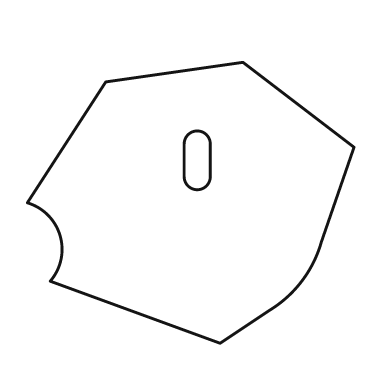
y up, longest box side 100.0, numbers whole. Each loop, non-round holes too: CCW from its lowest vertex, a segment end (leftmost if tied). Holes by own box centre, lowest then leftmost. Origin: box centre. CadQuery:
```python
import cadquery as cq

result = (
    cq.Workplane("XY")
    .moveTo(9.0, -43.0)
    .lineTo(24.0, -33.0)
    .threePointArc((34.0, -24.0), (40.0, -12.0))
    .lineTo(50.0, 17.0)
    .lineTo(16.0, 43.0)
    .lineTo(-26.0, 37.0)
    .lineTo(-50.0, 0.0)
    .threePointArc((-40.0, -10.0), (-43.0, -24.0))
    .close()
    .moveTo(-2.0, 8.0)
    .threePointArc((2.0, 4.0), (6.0, 8.0))
    .lineTo(6.0, 18.0)
    .threePointArc((2.0, 22.0), (-2.0, 18.0))
    .close()
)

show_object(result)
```